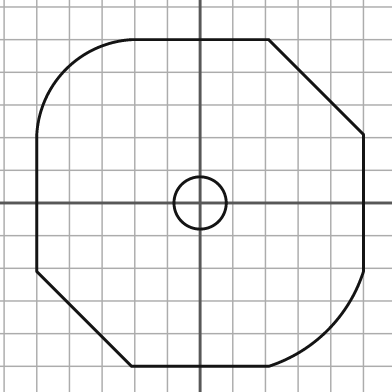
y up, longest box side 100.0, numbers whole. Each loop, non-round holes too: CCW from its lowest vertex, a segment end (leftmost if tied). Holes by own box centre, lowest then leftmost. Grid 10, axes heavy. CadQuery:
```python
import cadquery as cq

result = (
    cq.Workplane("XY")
    .moveTo(-21.0, -50.0)
    .lineTo(21.0, -50.0)
    .threePointArc((39.0, -39.0), (50.0, -21.0))
    .lineTo(50.0, 21.0)
    .lineTo(21.0, 50.0)
    .lineTo(-21.0, 50.0)
    .threePointArc((-41.0, 41.0), (-50.0, 21.0))
    .lineTo(-50.0, -21.0)
    .close()
    .moveTo(0.0, 0.0)
    .circle(8.0)
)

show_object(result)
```